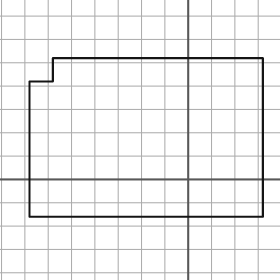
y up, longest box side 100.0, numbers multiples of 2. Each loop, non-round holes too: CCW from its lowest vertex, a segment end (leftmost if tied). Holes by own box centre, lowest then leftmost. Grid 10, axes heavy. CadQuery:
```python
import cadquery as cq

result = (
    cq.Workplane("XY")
    .moveTo(-68.0, -16.0)
    .lineTo(32.0, -16.0)
    .lineTo(32.0, 52.0)
    .lineTo(-58.0, 52.0)
    .lineTo(-58.0, 42.0)
    .lineTo(-68.0, 42.0)
    .close()
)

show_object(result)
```